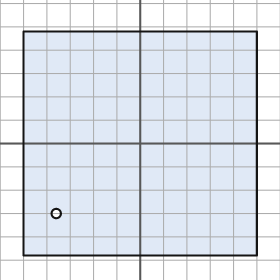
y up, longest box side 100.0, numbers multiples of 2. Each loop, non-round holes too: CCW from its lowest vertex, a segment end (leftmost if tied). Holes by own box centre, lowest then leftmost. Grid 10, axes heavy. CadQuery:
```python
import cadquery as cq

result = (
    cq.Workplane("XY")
    .moveTo(-50.0, -48.0)
    .lineTo(50.0, -48.0)
    .lineTo(50.0, 48.0)
    .lineTo(-50.0, 48.0)
    .close()
    .moveTo(-36.0, -30.0)
    .circle(2.0)
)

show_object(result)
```